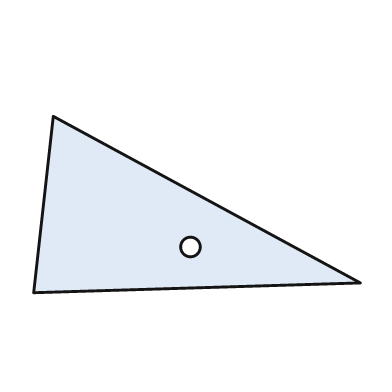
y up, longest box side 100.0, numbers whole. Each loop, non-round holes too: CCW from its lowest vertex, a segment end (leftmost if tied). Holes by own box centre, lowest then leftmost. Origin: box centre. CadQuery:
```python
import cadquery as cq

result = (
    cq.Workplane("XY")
    .moveTo(-50.0, -27.0)
    .lineTo(50.0, -24.0)
    .lineTo(-44.0, 27.0)
    .close()
    .moveTo(-2.0, -13.0)
    .circle(3.0)
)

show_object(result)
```